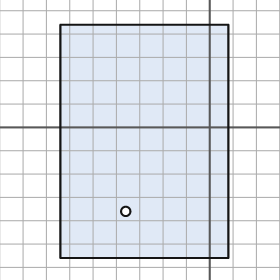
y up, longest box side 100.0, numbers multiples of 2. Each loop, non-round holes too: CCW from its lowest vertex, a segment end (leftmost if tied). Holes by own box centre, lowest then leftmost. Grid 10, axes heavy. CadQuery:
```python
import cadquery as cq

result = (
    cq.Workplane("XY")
    .moveTo(-64.0, -56.0)
    .lineTo(8.0, -56.0)
    .lineTo(8.0, 44.0)
    .lineTo(-64.0, 44.0)
    .close()
    .moveTo(-36.0, -36.0)
    .circle(2.0)
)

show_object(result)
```